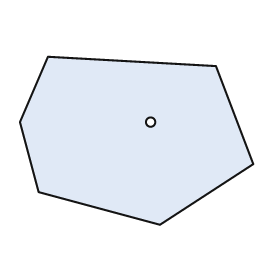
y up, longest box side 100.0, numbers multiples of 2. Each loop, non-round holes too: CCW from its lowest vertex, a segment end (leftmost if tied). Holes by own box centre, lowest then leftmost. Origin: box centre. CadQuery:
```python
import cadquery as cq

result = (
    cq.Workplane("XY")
    .moveTo(10.0, -36.0)
    .lineTo(50.0, -10.0)
    .lineTo(34.0, 32.0)
    .lineTo(-38.0, 36.0)
    .lineTo(-50.0, 8.0)
    .lineTo(-42.0, -22.0)
    .close()
    .moveTo(6.0, 8.0)
    .circle(2.0)
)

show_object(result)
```